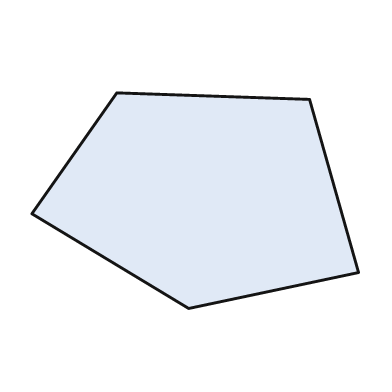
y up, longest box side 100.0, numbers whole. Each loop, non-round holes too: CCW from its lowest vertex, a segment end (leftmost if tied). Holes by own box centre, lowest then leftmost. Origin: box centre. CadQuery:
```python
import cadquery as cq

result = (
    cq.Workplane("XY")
    .moveTo(-2.0, -33.0)
    .lineTo(50.0, -22.0)
    .lineTo(35.0, 31.0)
    .lineTo(-24.0, 33.0)
    .lineTo(-50.0, -4.0)
    .close()
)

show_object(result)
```